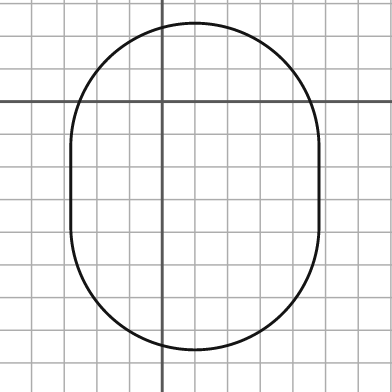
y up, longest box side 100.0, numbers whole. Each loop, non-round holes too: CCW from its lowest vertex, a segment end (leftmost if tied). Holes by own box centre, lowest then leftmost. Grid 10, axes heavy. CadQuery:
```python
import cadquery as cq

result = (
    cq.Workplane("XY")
    .moveTo(-28.0, -38.0)
    .threePointArc((10.0, -76.0), (48.0, -38.0))
    .lineTo(48.0, -14.0)
    .threePointArc((10.0, 24.0), (-28.0, -14.0))
    .close()
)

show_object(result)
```